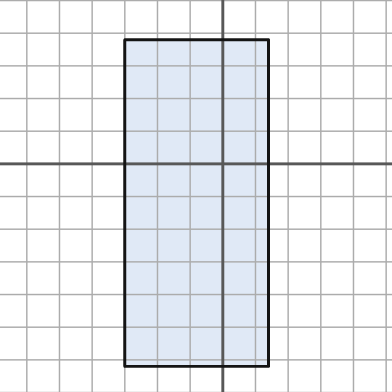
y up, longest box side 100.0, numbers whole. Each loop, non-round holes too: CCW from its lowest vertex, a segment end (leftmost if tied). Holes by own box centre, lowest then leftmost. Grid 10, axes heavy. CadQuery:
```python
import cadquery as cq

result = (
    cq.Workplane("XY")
    .moveTo(-30.0, -62.0)
    .lineTo(14.0, -62.0)
    .lineTo(14.0, 38.0)
    .lineTo(-30.0, 38.0)
    .close()
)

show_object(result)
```